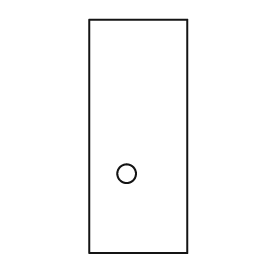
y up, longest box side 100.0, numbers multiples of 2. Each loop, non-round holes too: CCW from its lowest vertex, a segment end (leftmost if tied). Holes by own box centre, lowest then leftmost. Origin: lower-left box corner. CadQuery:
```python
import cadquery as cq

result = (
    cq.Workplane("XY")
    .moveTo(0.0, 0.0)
    .lineTo(42.0, 0.0)
    .lineTo(42.0, 100.0)
    .lineTo(0.0, 100.0)
    .close()
    .moveTo(16.0, 34.0)
    .circle(4.0)
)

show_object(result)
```